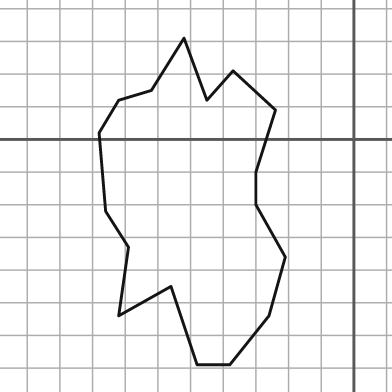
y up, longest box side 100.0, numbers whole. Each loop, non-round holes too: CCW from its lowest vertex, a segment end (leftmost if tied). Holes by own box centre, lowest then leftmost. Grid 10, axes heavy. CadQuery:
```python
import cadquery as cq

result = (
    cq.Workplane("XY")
    .moveTo(-48.0, -69.0)
    .lineTo(-38.0, -69.0)
    .lineTo(-26.0, -54.0)
    .lineTo(-21.0, -36.0)
    .lineTo(-30.0, -20.0)
    .lineTo(-30.0, -10.0)
    .lineTo(-24.0, 9.0)
    .lineTo(-37.0, 21.0)
    .lineTo(-45.0, 12.0)
    .lineTo(-52.0, 31.0)
    .lineTo(-62.0, 15.0)
    .lineTo(-72.0, 12.0)
    .lineTo(-78.0, 2.0)
    .lineTo(-76.0, -22.0)
    .lineTo(-69.0, -33.0)
    .lineTo(-72.0, -54.0)
    .lineTo(-56.0, -45.0)
    .close()
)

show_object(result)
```